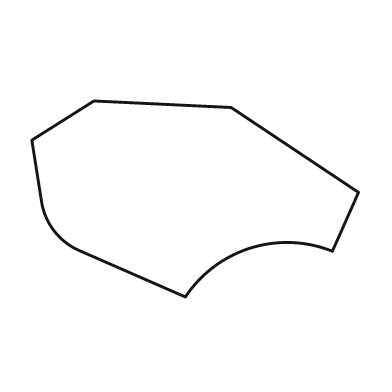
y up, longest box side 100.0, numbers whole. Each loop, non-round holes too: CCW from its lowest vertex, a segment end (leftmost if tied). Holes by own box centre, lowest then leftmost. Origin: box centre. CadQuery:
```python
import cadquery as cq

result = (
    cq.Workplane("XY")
    .moveTo(-3.0, -30.0)
    .threePointArc((17.0, -15.0), (42.0, -16.0))
    .lineTo(50.0, 2.0)
    .lineTo(11.0, 28.0)
    .lineTo(-31.0, 30.0)
    .lineTo(-50.0, 18.0)
    .lineTo(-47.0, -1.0)
    .threePointArc((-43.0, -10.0), (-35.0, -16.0))
    .close()
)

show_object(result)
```